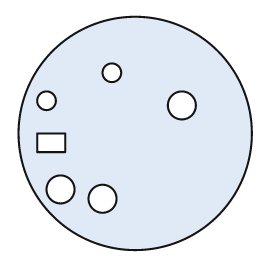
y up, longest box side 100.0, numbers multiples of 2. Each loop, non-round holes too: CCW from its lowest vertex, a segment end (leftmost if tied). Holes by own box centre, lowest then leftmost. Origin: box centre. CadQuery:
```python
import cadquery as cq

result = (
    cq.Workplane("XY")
    .moveTo(0.0, 0.0)
    .circle(50.0)
    .moveTo(-14.0, -28.0)
    .circle(6.0)
    .moveTo(-32.0, -24.0)
    .circle(6.0)
    .moveTo(-42.0, -8.0)
    .lineTo(-30.0, -8.0)
    .lineTo(-30.0, 0.0)
    .lineTo(-42.0, 0.0)
    .close()
    .moveTo(20.0, 12.0)
    .circle(6.0)
    .moveTo(-38.0, 14.0)
    .circle(4.0)
    .moveTo(-10.0, 26.0)
    .circle(4.0)
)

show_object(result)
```